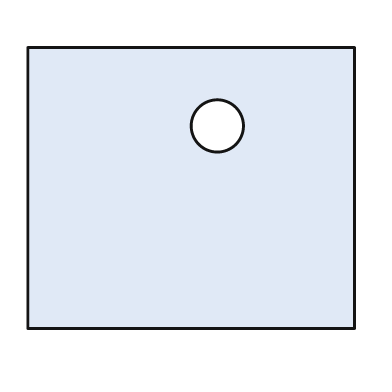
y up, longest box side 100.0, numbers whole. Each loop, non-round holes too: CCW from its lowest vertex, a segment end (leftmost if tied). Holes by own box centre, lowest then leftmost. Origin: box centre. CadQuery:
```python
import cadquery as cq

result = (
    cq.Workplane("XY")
    .moveTo(-50.0, -43.0)
    .lineTo(50.0, -43.0)
    .lineTo(50.0, 43.0)
    .lineTo(-50.0, 43.0)
    .close()
    .moveTo(8.0, 19.0)
    .circle(8.0)
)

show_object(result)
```